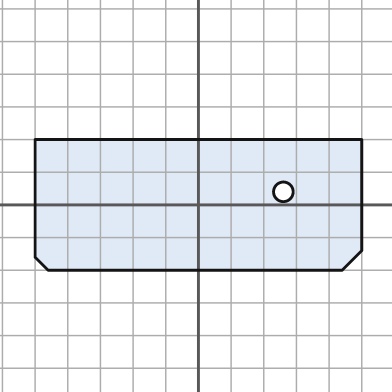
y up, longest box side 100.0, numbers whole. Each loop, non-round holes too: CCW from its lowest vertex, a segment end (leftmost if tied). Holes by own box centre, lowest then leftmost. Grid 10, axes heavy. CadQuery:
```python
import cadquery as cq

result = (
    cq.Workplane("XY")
    .moveTo(-46.0, -20.0)
    .lineTo(44.0, -20.0)
    .lineTo(50.0, -14.0)
    .lineTo(50.0, 20.0)
    .lineTo(-50.0, 20.0)
    .lineTo(-50.0, -16.0)
    .close()
    .moveTo(26.0, 4.0)
    .circle(3.0)
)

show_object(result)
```